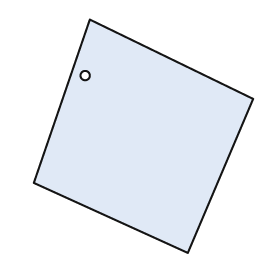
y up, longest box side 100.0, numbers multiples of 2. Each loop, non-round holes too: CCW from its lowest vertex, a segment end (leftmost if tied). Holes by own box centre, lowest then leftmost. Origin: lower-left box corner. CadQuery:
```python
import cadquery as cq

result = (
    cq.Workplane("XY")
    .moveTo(66.0, 0.0)
    .lineTo(94.0, 66.0)
    .lineTo(24.0, 100.0)
    .lineTo(0.0, 30.0)
    .close()
    .moveTo(22.0, 76.0)
    .circle(2.0)
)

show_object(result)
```